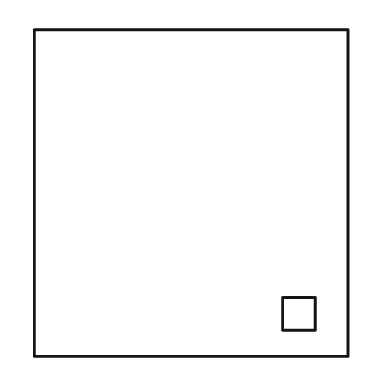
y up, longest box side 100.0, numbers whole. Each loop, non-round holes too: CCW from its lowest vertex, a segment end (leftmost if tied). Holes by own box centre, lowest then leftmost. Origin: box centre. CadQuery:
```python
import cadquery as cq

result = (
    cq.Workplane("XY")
    .moveTo(-48.0, -50.0)
    .lineTo(48.0, -50.0)
    .lineTo(48.0, 50.0)
    .lineTo(-48.0, 50.0)
    .close()
    .moveTo(28.0, -42.0)
    .lineTo(38.0, -42.0)
    .lineTo(38.0, -32.0)
    .lineTo(28.0, -32.0)
    .close()
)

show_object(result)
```